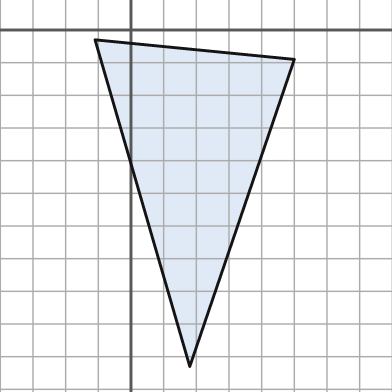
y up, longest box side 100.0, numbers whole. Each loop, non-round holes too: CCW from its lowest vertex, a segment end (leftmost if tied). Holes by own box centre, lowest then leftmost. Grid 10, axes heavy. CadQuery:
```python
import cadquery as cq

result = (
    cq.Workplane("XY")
    .moveTo(18.0, -103.0)
    .lineTo(50.0, -9.0)
    .lineTo(-11.0, -3.0)
    .close()
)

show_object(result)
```